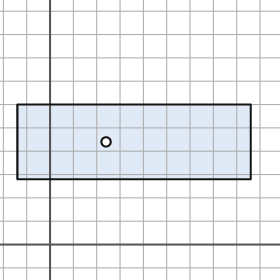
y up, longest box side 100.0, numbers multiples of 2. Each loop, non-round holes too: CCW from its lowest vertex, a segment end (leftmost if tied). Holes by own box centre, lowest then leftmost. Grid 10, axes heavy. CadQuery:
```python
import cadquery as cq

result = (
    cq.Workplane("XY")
    .moveTo(-14.0, 28.0)
    .lineTo(86.0, 28.0)
    .lineTo(86.0, 60.0)
    .lineTo(-14.0, 60.0)
    .close()
    .moveTo(24.0, 44.0)
    .circle(2.0)
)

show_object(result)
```